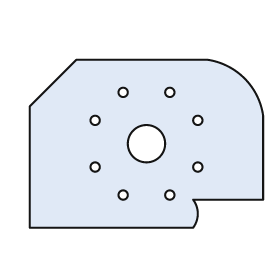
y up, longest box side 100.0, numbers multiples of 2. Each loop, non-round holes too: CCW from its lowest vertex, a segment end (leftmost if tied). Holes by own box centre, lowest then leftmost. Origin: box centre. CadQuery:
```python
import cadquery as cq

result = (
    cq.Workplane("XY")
    .moveTo(-50.0, -36.0)
    .lineTo(20.0, -36.0)
    .threePointArc((22.0, -30.0), (20.0, -24.0))
    .lineTo(50.0, -24.0)
    .lineTo(50.0, 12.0)
    .threePointArc((42.0, 28.0), (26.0, 36.0))
    .lineTo(-30.0, 36.0)
    .lineTo(-50.0, 16.0)
    .close()
    .moveTo(-10.0, -22.0)
    .circle(2.0)
    .moveTo(10.0, -22.0)
    .circle(2.0)
    .moveTo(-22.0, -10.0)
    .circle(2.0)
    .moveTo(22.0, -10.0)
    .circle(2.0)
    .moveTo(0.0, 0.0)
    .circle(8.0)
    .moveTo(-22.0, 10.0)
    .circle(2.0)
    .moveTo(22.0, 10.0)
    .circle(2.0)
    .moveTo(-10.0, 22.0)
    .circle(2.0)
    .moveTo(10.0, 22.0)
    .circle(2.0)
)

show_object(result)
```